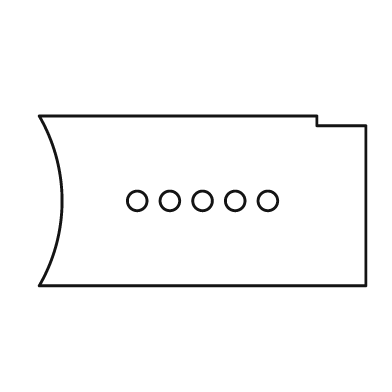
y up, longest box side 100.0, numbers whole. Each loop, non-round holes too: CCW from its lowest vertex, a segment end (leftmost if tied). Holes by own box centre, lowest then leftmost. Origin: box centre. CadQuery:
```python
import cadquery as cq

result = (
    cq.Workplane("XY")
    .moveTo(-50.0, -26.0)
    .lineTo(50.0, -26.0)
    .lineTo(50.0, 23.0)
    .lineTo(35.0, 23.0)
    .lineTo(35.0, 26.0)
    .lineTo(-50.0, 26.0)
    .threePointArc((-43.0, 0.0), (-50.0, -26.0))
    .close()
    .moveTo(-20.0, 0.0)
    .circle(3.0)
    .moveTo(-10.0, 0.0)
    .circle(3.0)
    .moveTo(0.0, 0.0)
    .circle(3.0)
    .moveTo(10.0, 0.0)
    .circle(3.0)
    .moveTo(20.0, 0.0)
    .circle(3.0)
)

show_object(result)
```